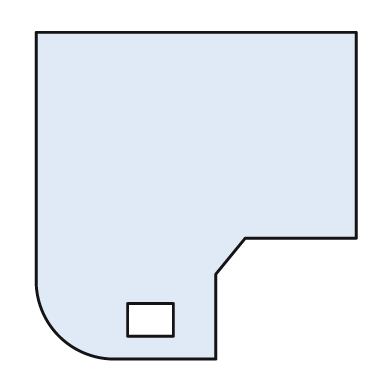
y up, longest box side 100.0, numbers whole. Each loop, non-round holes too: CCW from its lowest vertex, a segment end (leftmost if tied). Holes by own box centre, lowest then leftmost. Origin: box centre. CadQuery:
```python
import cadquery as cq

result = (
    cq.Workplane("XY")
    .moveTo(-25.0, -50.0)
    .lineTo(6.0, -50.0)
    .lineTo(6.0, -24.0)
    .lineTo(15.0, -13.0)
    .lineTo(49.0, -13.0)
    .lineTo(49.0, 50.0)
    .lineTo(-49.0, 50.0)
    .lineTo(-49.0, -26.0)
    .threePointArc((-42.0, -43.0), (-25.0, -50.0))
    .close()
    .moveTo(-21.0, -43.0)
    .lineTo(-7.0, -43.0)
    .lineTo(-7.0, -33.0)
    .lineTo(-21.0, -33.0)
    .close()
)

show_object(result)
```